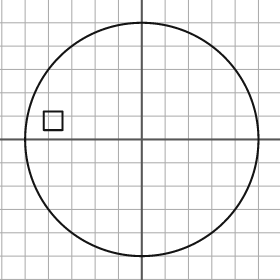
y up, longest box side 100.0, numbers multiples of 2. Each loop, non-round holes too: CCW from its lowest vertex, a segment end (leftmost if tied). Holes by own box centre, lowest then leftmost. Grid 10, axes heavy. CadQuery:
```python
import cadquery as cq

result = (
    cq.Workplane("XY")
    .moveTo(0.0, 0.0)
    .circle(50.0)
    .moveTo(-42.0, 4.0)
    .lineTo(-34.0, 4.0)
    .lineTo(-34.0, 12.0)
    .lineTo(-42.0, 12.0)
    .close()
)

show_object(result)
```